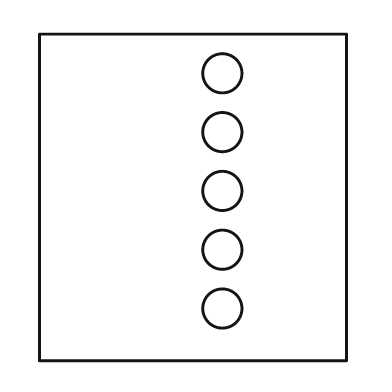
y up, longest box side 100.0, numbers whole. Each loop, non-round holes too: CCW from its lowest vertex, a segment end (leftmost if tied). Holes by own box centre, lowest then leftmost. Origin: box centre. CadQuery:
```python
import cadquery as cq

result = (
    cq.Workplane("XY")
    .moveTo(-47.0, -50.0)
    .lineTo(47.0, -50.0)
    .lineTo(47.0, 50.0)
    .lineTo(-47.0, 50.0)
    .close()
    .moveTo(9.0, -34.0)
    .circle(6.0)
    .moveTo(9.0, -16.0)
    .circle(6.0)
    .moveTo(9.0, 2.0)
    .circle(6.0)
    .moveTo(9.0, 20.0)
    .circle(6.0)
    .moveTo(9.0, 38.0)
    .circle(6.0)
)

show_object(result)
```